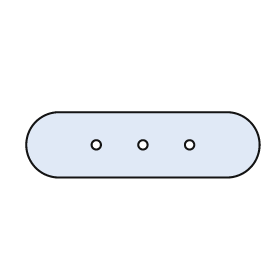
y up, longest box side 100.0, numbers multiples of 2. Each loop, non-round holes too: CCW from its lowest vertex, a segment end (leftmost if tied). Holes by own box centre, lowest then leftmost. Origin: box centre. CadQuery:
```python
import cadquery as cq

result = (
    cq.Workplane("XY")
    .moveTo(-36.0, -14.0)
    .lineTo(36.0, -14.0)
    .threePointArc((50.0, 0.0), (36.0, 14.0))
    .lineTo(-36.0, 14.0)
    .threePointArc((-50.0, 0.0), (-36.0, -14.0))
    .close()
    .moveTo(-20.0, 0.0)
    .circle(2.0)
    .moveTo(0.0, 0.0)
    .circle(2.0)
    .moveTo(20.0, 0.0)
    .circle(2.0)
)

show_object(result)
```